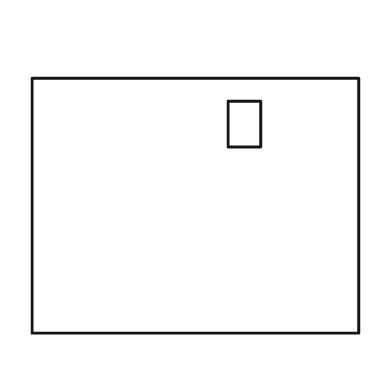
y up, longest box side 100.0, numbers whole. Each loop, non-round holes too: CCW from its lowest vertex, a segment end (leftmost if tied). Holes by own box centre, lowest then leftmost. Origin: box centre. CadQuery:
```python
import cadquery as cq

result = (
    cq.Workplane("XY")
    .moveTo(-50.0, -39.0)
    .lineTo(50.0, -39.0)
    .lineTo(50.0, 39.0)
    .lineTo(-50.0, 39.0)
    .close()
    .moveTo(10.0, 18.0)
    .lineTo(20.0, 18.0)
    .lineTo(20.0, 32.0)
    .lineTo(10.0, 32.0)
    .close()
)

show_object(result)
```